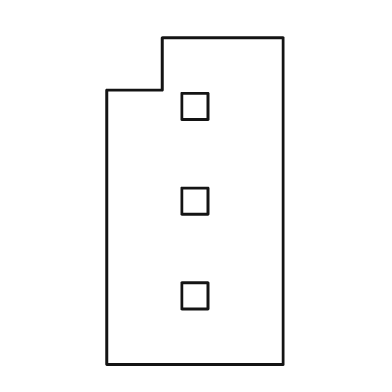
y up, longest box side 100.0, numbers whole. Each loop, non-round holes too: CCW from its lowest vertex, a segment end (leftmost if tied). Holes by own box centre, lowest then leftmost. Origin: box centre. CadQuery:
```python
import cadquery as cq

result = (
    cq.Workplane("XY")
    .moveTo(-27.0, -50.0)
    .lineTo(27.0, -50.0)
    .lineTo(27.0, 50.0)
    .lineTo(-10.0, 50.0)
    .lineTo(-10.0, 34.0)
    .lineTo(-27.0, 34.0)
    .close()
    .moveTo(-4.0, -33.0)
    .lineTo(4.0, -33.0)
    .lineTo(4.0, -25.0)
    .lineTo(-4.0, -25.0)
    .close()
    .moveTo(-4.0, -4.0)
    .lineTo(4.0, -4.0)
    .lineTo(4.0, 4.0)
    .lineTo(-4.0, 4.0)
    .close()
    .moveTo(-4.0, 25.0)
    .lineTo(4.0, 25.0)
    .lineTo(4.0, 33.0)
    .lineTo(-4.0, 33.0)
    .close()
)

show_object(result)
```